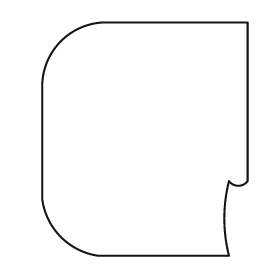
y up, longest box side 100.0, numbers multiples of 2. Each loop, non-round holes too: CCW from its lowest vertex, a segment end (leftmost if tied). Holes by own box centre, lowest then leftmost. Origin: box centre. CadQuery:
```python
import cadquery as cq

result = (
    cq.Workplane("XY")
    .moveTo(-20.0, -50.0)
    .lineTo(36.0, -50.0)
    .threePointArc((34.0, -34.0), (36.0, -18.0))
    .threePointArc((40.0, -20.0), (44.0, -18.0))
    .lineTo(44.0, 50.0)
    .lineTo(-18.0, 50.0)
    .threePointArc((-36.0, 42.0), (-44.0, 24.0))
    .lineTo(-44.0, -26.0)
    .threePointArc((-36.0, -42.0), (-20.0, -50.0))
    .close()
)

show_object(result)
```